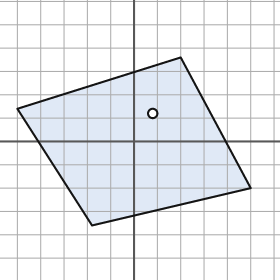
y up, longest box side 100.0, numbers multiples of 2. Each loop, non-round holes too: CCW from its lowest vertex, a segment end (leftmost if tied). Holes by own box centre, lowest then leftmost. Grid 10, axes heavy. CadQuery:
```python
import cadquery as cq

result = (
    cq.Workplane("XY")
    .moveTo(-18.0, -36.0)
    .lineTo(50.0, -20.0)
    .lineTo(20.0, 36.0)
    .lineTo(-50.0, 14.0)
    .close()
    .moveTo(8.0, 12.0)
    .circle(2.0)
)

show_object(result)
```